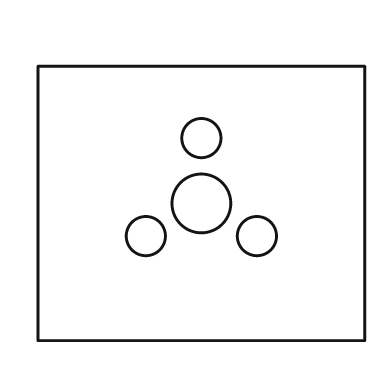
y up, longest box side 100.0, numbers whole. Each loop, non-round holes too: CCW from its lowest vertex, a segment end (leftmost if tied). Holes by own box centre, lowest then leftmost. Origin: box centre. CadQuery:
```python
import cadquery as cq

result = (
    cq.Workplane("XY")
    .moveTo(-50.0, -42.0)
    .lineTo(50.0, -42.0)
    .lineTo(50.0, 42.0)
    .lineTo(-50.0, 42.0)
    .close()
    .moveTo(-17.0, -10.0)
    .circle(6.0)
    .moveTo(17.0, -10.0)
    .circle(6.0)
    .moveTo(0.0, 0.0)
    .circle(9.0)
    .moveTo(0.0, 20.0)
    .circle(6.0)
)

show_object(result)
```